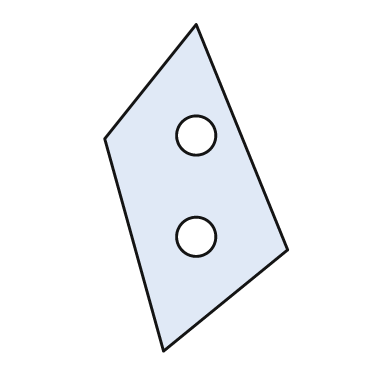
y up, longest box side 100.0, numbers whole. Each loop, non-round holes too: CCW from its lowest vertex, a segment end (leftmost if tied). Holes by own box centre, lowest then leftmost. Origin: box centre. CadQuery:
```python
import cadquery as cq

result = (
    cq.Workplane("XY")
    .moveTo(-10.0, -50.0)
    .lineTo(28.0, -19.0)
    .lineTo(0.0, 50.0)
    .lineTo(-28.0, 15.0)
    .close()
    .moveTo(0.0, -15.0)
    .circle(6.0)
    .moveTo(0.0, 16.0)
    .circle(6.0)
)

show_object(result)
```